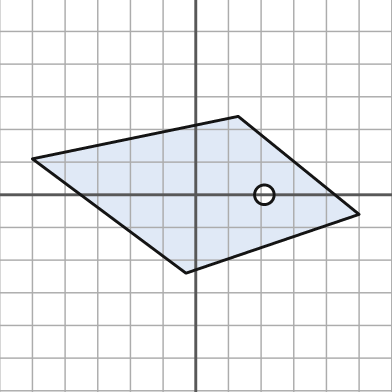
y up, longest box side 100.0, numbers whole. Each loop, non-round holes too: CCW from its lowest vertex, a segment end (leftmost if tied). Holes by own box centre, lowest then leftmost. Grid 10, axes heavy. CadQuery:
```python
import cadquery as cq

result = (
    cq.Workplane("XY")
    .moveTo(-3.0, -24.0)
    .lineTo(50.0, -6.0)
    .lineTo(13.0, 24.0)
    .lineTo(-50.0, 11.0)
    .close()
    .moveTo(21.0, 0.0)
    .circle(3.0)
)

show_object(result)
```